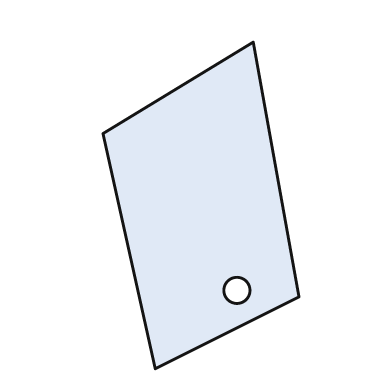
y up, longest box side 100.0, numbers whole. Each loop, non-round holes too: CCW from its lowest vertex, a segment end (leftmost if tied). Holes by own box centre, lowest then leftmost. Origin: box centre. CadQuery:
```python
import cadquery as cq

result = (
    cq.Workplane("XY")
    .moveTo(-14.0, -50.0)
    .lineTo(30.0, -28.0)
    .lineTo(16.0, 50.0)
    .lineTo(-30.0, 22.0)
    .close()
    .moveTo(11.0, -26.0)
    .circle(4.0)
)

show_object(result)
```